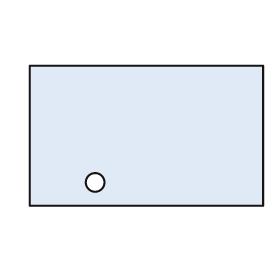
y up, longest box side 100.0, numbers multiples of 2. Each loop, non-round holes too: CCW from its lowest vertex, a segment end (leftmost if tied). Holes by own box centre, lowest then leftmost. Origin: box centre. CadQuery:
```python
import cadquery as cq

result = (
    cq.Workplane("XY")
    .moveTo(-50.0, -30.0)
    .lineTo(50.0, -30.0)
    .lineTo(50.0, 30.0)
    .lineTo(-50.0, 30.0)
    .close()
    .moveTo(-22.0, -20.0)
    .circle(4.0)
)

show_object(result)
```